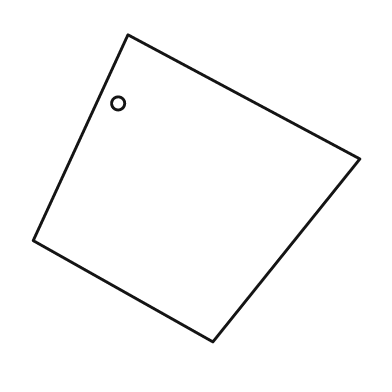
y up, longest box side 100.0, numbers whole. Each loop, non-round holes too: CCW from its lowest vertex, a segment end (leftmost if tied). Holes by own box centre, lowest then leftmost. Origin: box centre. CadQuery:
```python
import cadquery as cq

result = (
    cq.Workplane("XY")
    .moveTo(5.0, -47.0)
    .lineTo(50.0, 9.0)
    .lineTo(-21.0, 47.0)
    .lineTo(-50.0, -16.0)
    .close()
    .moveTo(-24.0, 26.0)
    .circle(2.0)
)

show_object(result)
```